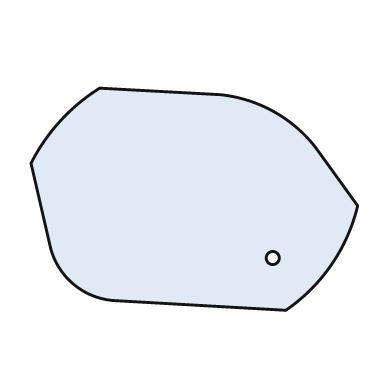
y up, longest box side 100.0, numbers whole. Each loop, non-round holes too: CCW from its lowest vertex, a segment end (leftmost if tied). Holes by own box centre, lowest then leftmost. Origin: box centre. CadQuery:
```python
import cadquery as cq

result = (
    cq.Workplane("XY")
    .moveTo(28.0, -34.0)
    .threePointArc((42.0, -20.0), (50.0, -2.0))
    .lineTo(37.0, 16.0)
    .threePointArc((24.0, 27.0), (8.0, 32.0))
    .lineTo(-29.0, 34.0)
    .threePointArc((-41.0, 24.0), (-50.0, 11.0))
    .lineTo(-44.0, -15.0)
    .threePointArc((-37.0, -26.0), (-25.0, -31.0))
    .close()
    .moveTo(24.0, -18.0)
    .circle(2.0)
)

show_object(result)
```